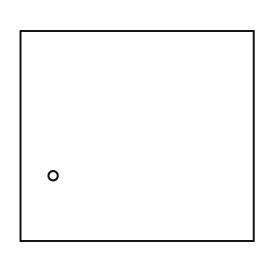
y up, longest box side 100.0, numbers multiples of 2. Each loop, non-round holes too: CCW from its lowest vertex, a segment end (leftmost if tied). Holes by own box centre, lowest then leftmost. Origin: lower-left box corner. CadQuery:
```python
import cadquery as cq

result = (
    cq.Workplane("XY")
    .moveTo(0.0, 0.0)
    .lineTo(100.0, 0.0)
    .lineTo(100.0, 90.0)
    .lineTo(0.0, 90.0)
    .close()
    .moveTo(14.0, 28.0)
    .circle(2.0)
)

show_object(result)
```